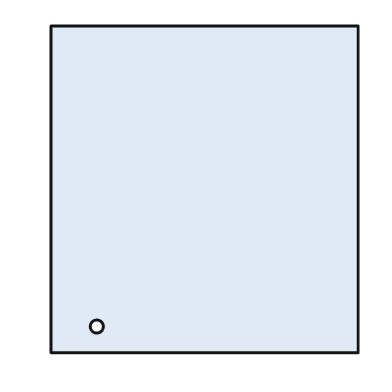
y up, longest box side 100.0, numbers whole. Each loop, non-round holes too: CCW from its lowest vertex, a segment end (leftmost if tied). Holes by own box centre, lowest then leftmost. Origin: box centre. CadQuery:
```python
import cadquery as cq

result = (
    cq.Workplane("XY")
    .moveTo(-47.0, -50.0)
    .lineTo(47.0, -50.0)
    .lineTo(47.0, 50.0)
    .lineTo(-47.0, 50.0)
    .close()
    .moveTo(-33.0, -42.0)
    .circle(2.0)
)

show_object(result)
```